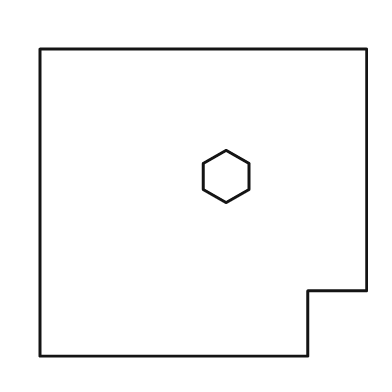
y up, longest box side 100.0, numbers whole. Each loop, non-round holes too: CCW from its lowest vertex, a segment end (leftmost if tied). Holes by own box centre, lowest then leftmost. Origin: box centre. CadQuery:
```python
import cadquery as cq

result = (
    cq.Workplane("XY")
    .moveTo(-50.0, -47.0)
    .lineTo(32.0, -47.0)
    .lineTo(32.0, -27.0)
    .lineTo(50.0, -27.0)
    .lineTo(50.0, 47.0)
    .lineTo(-50.0, 47.0)
    .close()
    .moveTo(7.0, 0.0)
    .lineTo(14.0, 4.0)
    .lineTo(14.0, 12.0)
    .lineTo(7.0, 16.0)
    .lineTo(0.0, 12.0)
    .lineTo(0.0, 4.0)
    .close()
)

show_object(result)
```